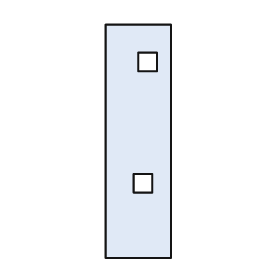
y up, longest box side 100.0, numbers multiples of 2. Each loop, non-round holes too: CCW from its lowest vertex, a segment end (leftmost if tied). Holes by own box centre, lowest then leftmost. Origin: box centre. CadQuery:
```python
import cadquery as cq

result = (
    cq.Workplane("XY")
    .moveTo(-14.0, -50.0)
    .lineTo(14.0, -50.0)
    .lineTo(14.0, 50.0)
    .lineTo(-14.0, 50.0)
    .close()
    .moveTo(-2.0, -22.0)
    .lineTo(6.0, -22.0)
    .lineTo(6.0, -14.0)
    .lineTo(-2.0, -14.0)
    .close()
    .moveTo(0.0, 30.0)
    .lineTo(8.0, 30.0)
    .lineTo(8.0, 38.0)
    .lineTo(0.0, 38.0)
    .close()
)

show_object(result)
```